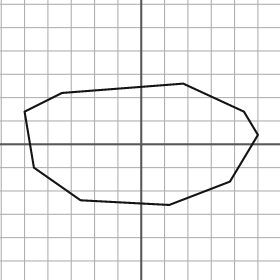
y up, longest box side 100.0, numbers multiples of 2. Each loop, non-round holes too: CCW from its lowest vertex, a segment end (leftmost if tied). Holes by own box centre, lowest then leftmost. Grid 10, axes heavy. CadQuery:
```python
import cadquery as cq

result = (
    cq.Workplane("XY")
    .moveTo(12.0, -26.0)
    .lineTo(38.0, -16.0)
    .lineTo(50.0, 4.0)
    .lineTo(44.0, 14.0)
    .lineTo(18.0, 26.0)
    .lineTo(-34.0, 22.0)
    .lineTo(-50.0, 14.0)
    .lineTo(-46.0, -10.0)
    .lineTo(-26.0, -24.0)
    .close()
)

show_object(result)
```